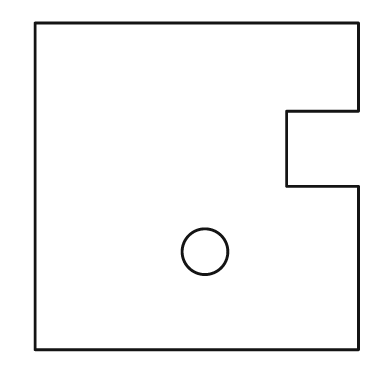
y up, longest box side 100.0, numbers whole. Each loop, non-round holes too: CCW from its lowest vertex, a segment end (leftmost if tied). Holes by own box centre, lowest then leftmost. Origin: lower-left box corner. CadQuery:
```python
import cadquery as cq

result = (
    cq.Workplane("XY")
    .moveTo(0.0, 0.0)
    .lineTo(99.0, 0.0)
    .lineTo(99.0, 50.0)
    .lineTo(77.0, 50.0)
    .lineTo(77.0, 73.0)
    .lineTo(99.0, 73.0)
    .lineTo(99.0, 100.0)
    .lineTo(0.0, 100.0)
    .close()
    .moveTo(52.0, 30.0)
    .circle(7.0)
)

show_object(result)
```